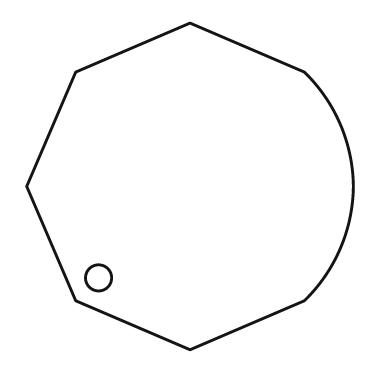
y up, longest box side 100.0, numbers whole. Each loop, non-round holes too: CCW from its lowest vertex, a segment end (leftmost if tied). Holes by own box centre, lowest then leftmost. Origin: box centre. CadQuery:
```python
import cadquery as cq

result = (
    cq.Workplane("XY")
    .moveTo(0.0, -50.0)
    .lineTo(35.0, -35.0)
    .threePointArc((46.0, -19.0), (50.0, 0.0))
    .threePointArc((46.0, 19.0), (35.0, 35.0))
    .lineTo(0.0, 50.0)
    .lineTo(-35.0, 35.0)
    .lineTo(-50.0, 0.0)
    .lineTo(-35.0, -35.0)
    .close()
    .moveTo(-28.0, -28.0)
    .circle(4.0)
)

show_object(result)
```